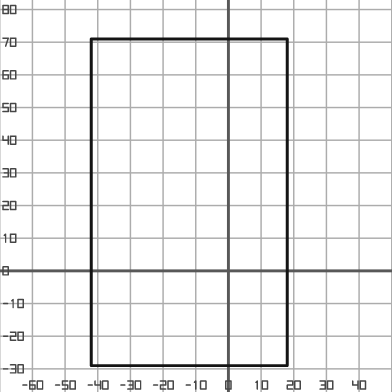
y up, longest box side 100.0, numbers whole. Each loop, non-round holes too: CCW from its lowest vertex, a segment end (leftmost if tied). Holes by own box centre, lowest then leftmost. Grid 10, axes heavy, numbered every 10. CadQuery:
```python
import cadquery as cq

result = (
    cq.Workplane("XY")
    .moveTo(-42.0, -29.0)
    .lineTo(18.0, -29.0)
    .lineTo(18.0, 71.0)
    .lineTo(-42.0, 71.0)
    .close()
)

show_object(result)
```